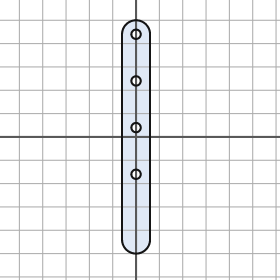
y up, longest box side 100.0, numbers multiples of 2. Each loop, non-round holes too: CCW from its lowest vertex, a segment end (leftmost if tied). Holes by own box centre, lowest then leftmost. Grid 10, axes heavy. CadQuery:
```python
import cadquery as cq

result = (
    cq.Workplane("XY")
    .moveTo(-6.0, -44.0)
    .threePointArc((0.0, -50.0), (6.0, -44.0))
    .lineTo(6.0, 44.0)
    .threePointArc((0.0, 50.0), (-6.0, 44.0))
    .close()
    .moveTo(0.0, -16.0)
    .circle(2.0)
    .moveTo(0.0, 4.0)
    .circle(2.0)
    .moveTo(0.0, 24.0)
    .circle(2.0)
    .moveTo(0.0, 44.0)
    .circle(2.0)
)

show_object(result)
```